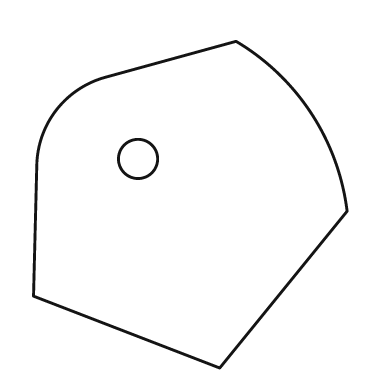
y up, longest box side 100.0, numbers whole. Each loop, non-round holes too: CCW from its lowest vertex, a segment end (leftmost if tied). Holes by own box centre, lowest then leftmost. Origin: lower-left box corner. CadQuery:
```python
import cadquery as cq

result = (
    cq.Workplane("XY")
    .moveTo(57.0, 0.0)
    .lineTo(96.0, 48.0)
    .threePointArc((85.0, 78.0), (62.0, 100.0))
    .lineTo(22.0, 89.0)
    .threePointArc((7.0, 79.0), (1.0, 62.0))
    .lineTo(0.0, 22.0)
    .close()
    .moveTo(32.0, 64.0)
    .circle(6.0)
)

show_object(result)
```